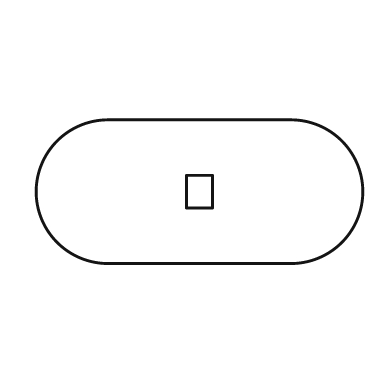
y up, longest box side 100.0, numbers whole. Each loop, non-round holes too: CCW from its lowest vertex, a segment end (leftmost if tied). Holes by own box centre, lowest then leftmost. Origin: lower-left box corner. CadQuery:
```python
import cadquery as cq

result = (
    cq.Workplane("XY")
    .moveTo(22.0, 0.0)
    .lineTo(78.0, 0.0)
    .threePointArc((100.0, 22.0), (78.0, 44.0))
    .lineTo(22.0, 44.0)
    .threePointArc((0.0, 22.0), (22.0, 0.0))
    .close()
    .moveTo(46.0, 17.0)
    .lineTo(54.0, 17.0)
    .lineTo(54.0, 27.0)
    .lineTo(46.0, 27.0)
    .close()
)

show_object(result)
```